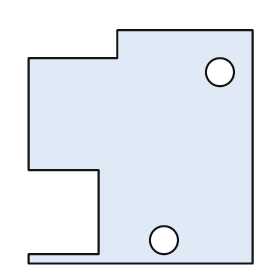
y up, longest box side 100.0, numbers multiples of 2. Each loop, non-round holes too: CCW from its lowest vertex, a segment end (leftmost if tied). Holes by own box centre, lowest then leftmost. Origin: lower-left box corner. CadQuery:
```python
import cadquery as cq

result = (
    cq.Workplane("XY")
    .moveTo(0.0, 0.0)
    .lineTo(96.0, 0.0)
    .lineTo(96.0, 100.0)
    .lineTo(38.0, 100.0)
    .lineTo(38.0, 88.0)
    .lineTo(0.0, 88.0)
    .lineTo(0.0, 40.0)
    .lineTo(30.0, 40.0)
    .lineTo(30.0, 4.0)
    .lineTo(0.0, 4.0)
    .close()
    .moveTo(58.0, 10.0)
    .circle(6.0)
    .moveTo(82.0, 82.0)
    .circle(6.0)
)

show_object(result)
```